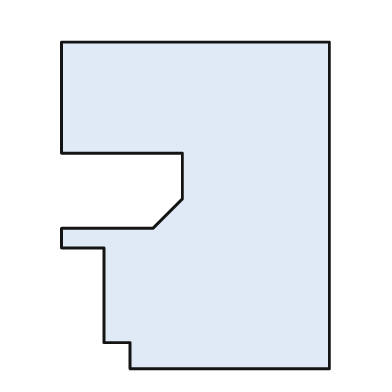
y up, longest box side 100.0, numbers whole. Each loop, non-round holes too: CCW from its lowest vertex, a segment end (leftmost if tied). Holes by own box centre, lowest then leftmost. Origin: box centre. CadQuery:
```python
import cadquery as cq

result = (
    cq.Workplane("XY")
    .moveTo(-20.0, -50.0)
    .lineTo(41.0, -50.0)
    .lineTo(41.0, 50.0)
    .lineTo(-41.0, 50.0)
    .lineTo(-41.0, 16.0)
    .lineTo(-4.0, 16.0)
    .lineTo(-4.0, 2.0)
    .lineTo(-13.0, -7.0)
    .lineTo(-41.0, -7.0)
    .lineTo(-41.0, -13.0)
    .lineTo(-28.0, -13.0)
    .lineTo(-28.0, -42.0)
    .lineTo(-20.0, -42.0)
    .close()
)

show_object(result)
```